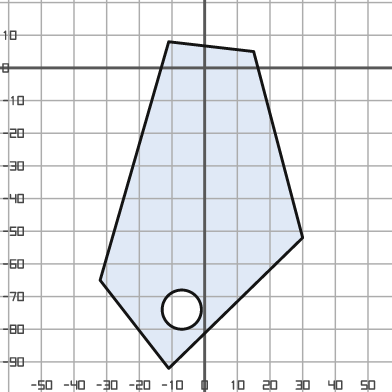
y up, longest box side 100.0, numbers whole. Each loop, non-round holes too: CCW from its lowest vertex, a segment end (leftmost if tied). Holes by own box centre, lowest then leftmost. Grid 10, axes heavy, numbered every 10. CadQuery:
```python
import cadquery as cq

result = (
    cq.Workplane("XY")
    .moveTo(-11.0, -92.0)
    .lineTo(30.0, -52.0)
    .lineTo(15.0, 5.0)
    .lineTo(-11.0, 8.0)
    .lineTo(-32.0, -65.0)
    .close()
    .moveTo(-7.0, -74.0)
    .circle(6.0)
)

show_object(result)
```